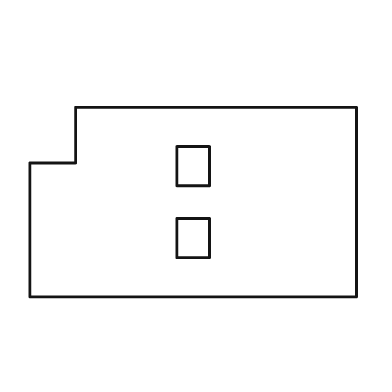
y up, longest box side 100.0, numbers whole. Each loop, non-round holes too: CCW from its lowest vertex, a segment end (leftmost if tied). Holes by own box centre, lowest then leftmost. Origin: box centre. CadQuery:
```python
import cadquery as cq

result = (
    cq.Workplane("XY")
    .moveTo(-50.0, -29.0)
    .lineTo(50.0, -29.0)
    .lineTo(50.0, 29.0)
    .lineTo(-36.0, 29.0)
    .lineTo(-36.0, 12.0)
    .lineTo(-50.0, 12.0)
    .close()
    .moveTo(-5.0, -17.0)
    .lineTo(5.0, -17.0)
    .lineTo(5.0, -5.0)
    .lineTo(-5.0, -5.0)
    .close()
    .moveTo(-5.0, 5.0)
    .lineTo(5.0, 5.0)
    .lineTo(5.0, 17.0)
    .lineTo(-5.0, 17.0)
    .close()
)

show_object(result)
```